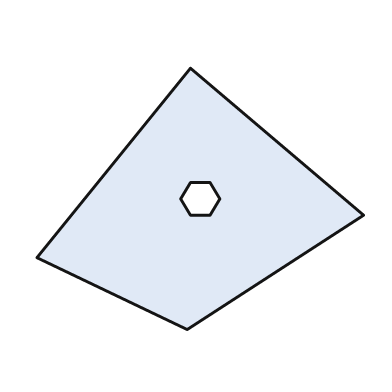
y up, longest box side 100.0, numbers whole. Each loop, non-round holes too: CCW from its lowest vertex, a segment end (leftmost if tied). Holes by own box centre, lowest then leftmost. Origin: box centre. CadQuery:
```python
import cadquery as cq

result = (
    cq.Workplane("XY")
    .moveTo(-4.0, -40.0)
    .lineTo(50.0, -5.0)
    .lineTo(-3.0, 40.0)
    .lineTo(-50.0, -18.0)
    .close()
    .moveTo(-3.0, -5.0)
    .lineTo(3.0, -5.0)
    .lineTo(6.0, 0.0)
    .lineTo(3.0, 5.0)
    .lineTo(-3.0, 5.0)
    .lineTo(-6.0, 0.0)
    .close()
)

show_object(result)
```